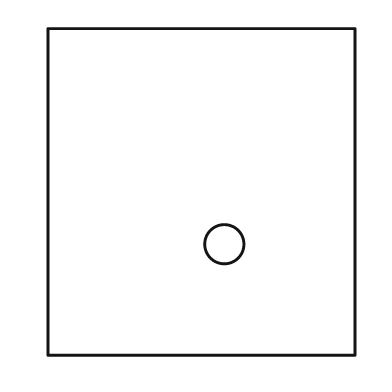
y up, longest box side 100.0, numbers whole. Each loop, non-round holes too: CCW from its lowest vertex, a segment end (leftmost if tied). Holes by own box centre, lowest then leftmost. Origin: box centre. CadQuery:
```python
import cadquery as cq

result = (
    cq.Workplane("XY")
    .moveTo(-47.0, -50.0)
    .lineTo(47.0, -50.0)
    .lineTo(47.0, 50.0)
    .lineTo(-47.0, 50.0)
    .close()
    .moveTo(7.0, -16.0)
    .circle(6.0)
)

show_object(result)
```